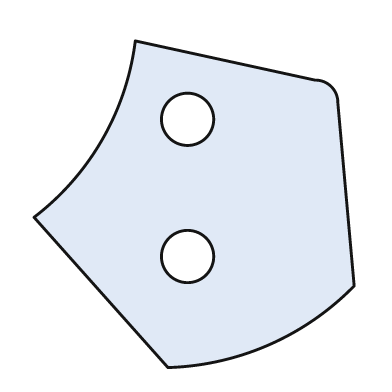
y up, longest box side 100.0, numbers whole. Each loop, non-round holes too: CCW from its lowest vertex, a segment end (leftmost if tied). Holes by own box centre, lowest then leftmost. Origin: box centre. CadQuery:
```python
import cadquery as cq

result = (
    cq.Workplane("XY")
    .moveTo(-8.0, -50.0)
    .threePointArc((23.0, -43.0), (49.0, -25.0))
    .lineTo(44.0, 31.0)
    .threePointArc((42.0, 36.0), (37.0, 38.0))
    .lineTo(-18.0, 50.0)
    .threePointArc((-28.0, 20.0), (-49.0, -4.0))
    .close()
    .moveTo(-2.0, -16.0)
    .circle(8.0)
    .moveTo(-2.0, 26.0)
    .circle(8.0)
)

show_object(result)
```